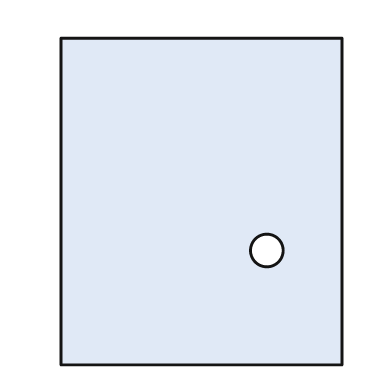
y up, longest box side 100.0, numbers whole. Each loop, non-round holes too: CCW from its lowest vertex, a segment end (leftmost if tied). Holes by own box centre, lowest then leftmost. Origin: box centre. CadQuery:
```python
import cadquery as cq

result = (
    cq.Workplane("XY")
    .moveTo(-43.0, -50.0)
    .lineTo(43.0, -50.0)
    .lineTo(43.0, 50.0)
    .lineTo(-43.0, 50.0)
    .close()
    .moveTo(20.0, -15.0)
    .circle(5.0)
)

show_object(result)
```